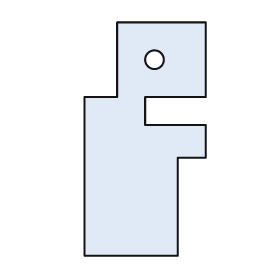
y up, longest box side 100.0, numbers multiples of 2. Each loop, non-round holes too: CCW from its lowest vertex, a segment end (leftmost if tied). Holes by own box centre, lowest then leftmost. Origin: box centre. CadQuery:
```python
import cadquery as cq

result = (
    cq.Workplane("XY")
    .moveTo(-26.0, -50.0)
    .lineTo(14.0, -50.0)
    .lineTo(14.0, -8.0)
    .lineTo(26.0, -8.0)
    .lineTo(26.0, 6.0)
    .lineTo(0.0, 6.0)
    .lineTo(0.0, 18.0)
    .lineTo(26.0, 18.0)
    .lineTo(26.0, 50.0)
    .lineTo(-12.0, 50.0)
    .lineTo(-12.0, 18.0)
    .lineTo(-26.0, 18.0)
    .close()
    .moveTo(4.0, 34.0)
    .circle(4.0)
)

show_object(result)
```